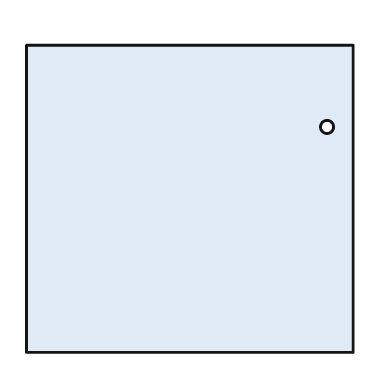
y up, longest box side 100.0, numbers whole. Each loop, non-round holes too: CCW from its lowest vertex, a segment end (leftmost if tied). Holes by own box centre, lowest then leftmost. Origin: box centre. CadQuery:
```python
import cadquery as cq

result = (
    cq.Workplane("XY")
    .moveTo(-50.0, -47.0)
    .lineTo(50.0, -47.0)
    .lineTo(50.0, 47.0)
    .lineTo(-50.0, 47.0)
    .close()
    .moveTo(42.0, 22.0)
    .circle(2.0)
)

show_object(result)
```